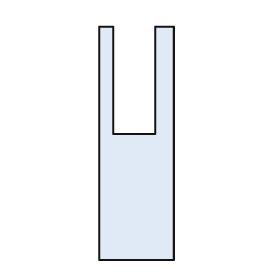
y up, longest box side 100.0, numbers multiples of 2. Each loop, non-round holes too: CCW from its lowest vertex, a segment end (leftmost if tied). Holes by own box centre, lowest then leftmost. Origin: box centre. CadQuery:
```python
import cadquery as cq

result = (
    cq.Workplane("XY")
    .moveTo(-16.0, -50.0)
    .lineTo(16.0, -50.0)
    .lineTo(16.0, 50.0)
    .lineTo(8.0, 50.0)
    .lineTo(8.0, 4.0)
    .lineTo(-10.0, 4.0)
    .lineTo(-10.0, 50.0)
    .lineTo(-16.0, 50.0)
    .close()
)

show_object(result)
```